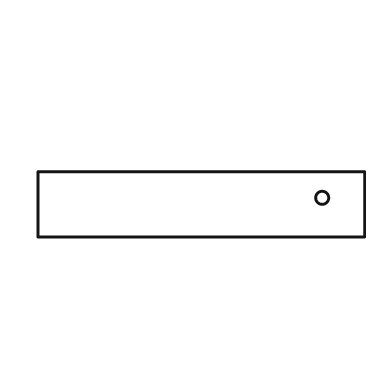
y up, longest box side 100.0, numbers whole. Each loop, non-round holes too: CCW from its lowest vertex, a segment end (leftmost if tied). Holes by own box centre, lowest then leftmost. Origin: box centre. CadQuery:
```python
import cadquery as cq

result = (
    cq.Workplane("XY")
    .moveTo(-50.0, -10.0)
    .lineTo(50.0, -10.0)
    .lineTo(50.0, 10.0)
    .lineTo(-50.0, 10.0)
    .close()
    .moveTo(37.0, 2.0)
    .circle(2.0)
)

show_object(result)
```